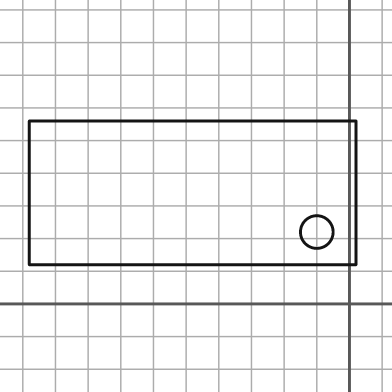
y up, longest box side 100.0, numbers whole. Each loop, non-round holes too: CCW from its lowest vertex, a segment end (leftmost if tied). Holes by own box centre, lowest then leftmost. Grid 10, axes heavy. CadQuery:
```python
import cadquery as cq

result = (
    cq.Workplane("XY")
    .moveTo(-98.0, 12.0)
    .lineTo(2.0, 12.0)
    .lineTo(2.0, 56.0)
    .lineTo(-98.0, 56.0)
    .close()
    .moveTo(-10.0, 22.0)
    .circle(5.0)
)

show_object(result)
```